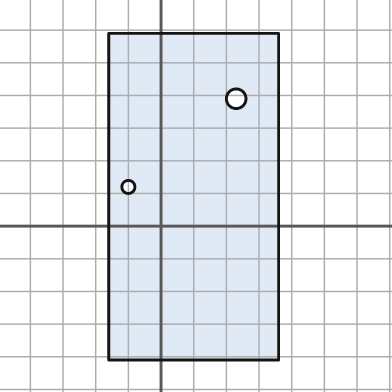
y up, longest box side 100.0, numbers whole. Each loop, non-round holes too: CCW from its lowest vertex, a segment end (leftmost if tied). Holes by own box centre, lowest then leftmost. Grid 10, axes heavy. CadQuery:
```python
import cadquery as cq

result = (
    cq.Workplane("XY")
    .moveTo(-16.0, -41.0)
    .lineTo(36.0, -41.0)
    .lineTo(36.0, 59.0)
    .lineTo(-16.0, 59.0)
    .close()
    .moveTo(-10.0, 12.0)
    .circle(2.0)
    .moveTo(23.0, 39.0)
    .circle(3.0)
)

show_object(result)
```